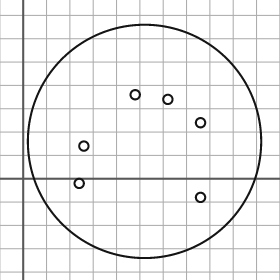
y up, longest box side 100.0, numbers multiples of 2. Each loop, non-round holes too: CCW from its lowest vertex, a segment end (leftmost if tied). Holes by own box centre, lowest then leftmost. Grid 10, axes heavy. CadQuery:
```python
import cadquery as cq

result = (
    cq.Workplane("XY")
    .moveTo(52.0, 16.0)
    .circle(50.0)
    .moveTo(76.0, -8.0)
    .circle(2.0)
    .moveTo(24.0, -2.0)
    .circle(2.0)
    .moveTo(26.0, 14.0)
    .circle(2.0)
    .moveTo(76.0, 24.0)
    .circle(2.0)
    .moveTo(62.0, 34.0)
    .circle(2.0)
    .moveTo(48.0, 36.0)
    .circle(2.0)
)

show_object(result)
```